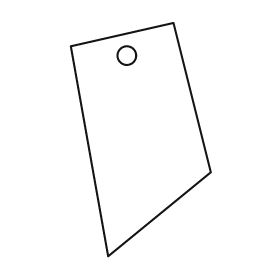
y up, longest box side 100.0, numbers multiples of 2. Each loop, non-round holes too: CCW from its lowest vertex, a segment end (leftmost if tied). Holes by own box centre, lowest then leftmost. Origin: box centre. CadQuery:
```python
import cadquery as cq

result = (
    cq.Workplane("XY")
    .moveTo(-14.0, -50.0)
    .lineTo(30.0, -14.0)
    .lineTo(14.0, 50.0)
    .lineTo(-30.0, 40.0)
    .close()
    .moveTo(-6.0, 36.0)
    .circle(4.0)
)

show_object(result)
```